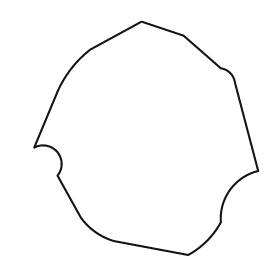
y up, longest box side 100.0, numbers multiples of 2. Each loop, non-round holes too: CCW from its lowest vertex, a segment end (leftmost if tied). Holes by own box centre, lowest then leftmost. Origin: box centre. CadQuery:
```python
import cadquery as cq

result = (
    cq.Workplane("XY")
    .moveTo(18.0, -50.0)
    .threePointArc((26.0, -44.0), (32.0, -36.0))
    .threePointArc((36.0, -22.0), (48.0, -14.0))
    .lineTo(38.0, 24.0)
    .threePointArc((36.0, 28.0), (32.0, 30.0))
    .lineTo(16.0, 44.0)
    .lineTo(-2.0, 50.0)
    .lineTo(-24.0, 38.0)
    .threePointArc((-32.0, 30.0), (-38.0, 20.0))
    .lineTo(-48.0, -4.0)
    .threePointArc((-38.0, -6.0), (-38.0, -16.0))
    .lineTo(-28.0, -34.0)
    .threePointArc((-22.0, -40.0), (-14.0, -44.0))
    .close()
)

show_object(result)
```